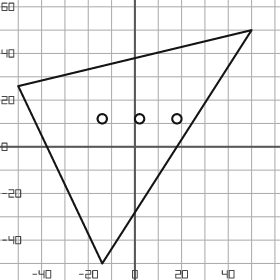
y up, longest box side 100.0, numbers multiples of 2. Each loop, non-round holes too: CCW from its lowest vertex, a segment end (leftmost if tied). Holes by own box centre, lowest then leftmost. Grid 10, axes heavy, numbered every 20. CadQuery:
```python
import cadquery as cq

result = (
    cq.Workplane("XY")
    .moveTo(-14.0, -50.0)
    .lineTo(50.0, 50.0)
    .lineTo(-50.0, 26.0)
    .close()
    .moveTo(-14.0, 12.0)
    .circle(2.0)
    .moveTo(2.0, 12.0)
    .circle(2.0)
    .moveTo(18.0, 12.0)
    .circle(2.0)
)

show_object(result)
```